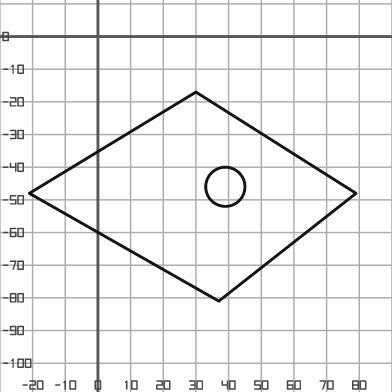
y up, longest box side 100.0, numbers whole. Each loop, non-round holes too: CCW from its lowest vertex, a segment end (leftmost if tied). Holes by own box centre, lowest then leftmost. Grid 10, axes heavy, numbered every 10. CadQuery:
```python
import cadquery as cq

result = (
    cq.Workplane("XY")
    .moveTo(37.0, -81.0)
    .lineTo(79.0, -48.0)
    .lineTo(30.0, -17.0)
    .lineTo(-21.0, -48.0)
    .close()
    .moveTo(39.0, -46.0)
    .circle(6.0)
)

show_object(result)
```